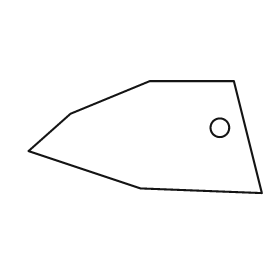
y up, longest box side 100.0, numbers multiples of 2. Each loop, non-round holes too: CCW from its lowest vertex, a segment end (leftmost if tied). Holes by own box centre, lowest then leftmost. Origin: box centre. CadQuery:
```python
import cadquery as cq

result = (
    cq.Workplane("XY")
    .moveTo(50.0, -24.0)
    .lineTo(38.0, 24.0)
    .lineTo(2.0, 24.0)
    .lineTo(-32.0, 10.0)
    .lineTo(-50.0, -6.0)
    .lineTo(-2.0, -22.0)
    .close()
    .moveTo(32.0, 4.0)
    .circle(4.0)
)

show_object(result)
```